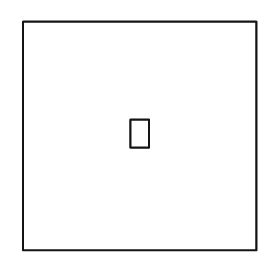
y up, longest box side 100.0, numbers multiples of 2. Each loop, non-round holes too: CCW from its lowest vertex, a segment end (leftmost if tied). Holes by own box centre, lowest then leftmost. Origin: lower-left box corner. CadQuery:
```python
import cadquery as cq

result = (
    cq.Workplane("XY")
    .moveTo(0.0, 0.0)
    .lineTo(100.0, 0.0)
    .lineTo(100.0, 98.0)
    .lineTo(0.0, 98.0)
    .close()
    .moveTo(46.0, 44.0)
    .lineTo(54.0, 44.0)
    .lineTo(54.0, 56.0)
    .lineTo(46.0, 56.0)
    .close()
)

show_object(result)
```